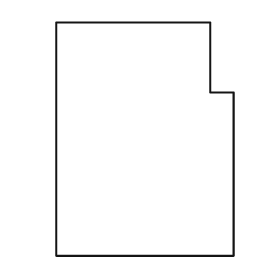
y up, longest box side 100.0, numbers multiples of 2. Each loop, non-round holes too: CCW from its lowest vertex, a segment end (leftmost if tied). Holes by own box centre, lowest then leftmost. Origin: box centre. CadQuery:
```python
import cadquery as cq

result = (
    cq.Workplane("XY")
    .moveTo(-38.0, -50.0)
    .lineTo(38.0, -50.0)
    .lineTo(38.0, 20.0)
    .lineTo(28.0, 20.0)
    .lineTo(28.0, 50.0)
    .lineTo(-38.0, 50.0)
    .close()
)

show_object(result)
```